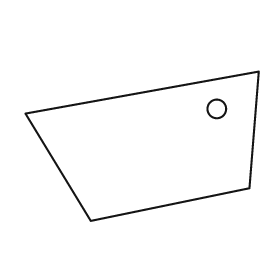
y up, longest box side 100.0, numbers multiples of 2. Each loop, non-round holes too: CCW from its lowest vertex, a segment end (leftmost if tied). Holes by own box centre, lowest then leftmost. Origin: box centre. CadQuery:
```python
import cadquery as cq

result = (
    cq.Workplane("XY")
    .moveTo(-22.0, -32.0)
    .lineTo(46.0, -18.0)
    .lineTo(50.0, 32.0)
    .lineTo(-50.0, 14.0)
    .close()
    .moveTo(32.0, 16.0)
    .circle(4.0)
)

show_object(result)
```